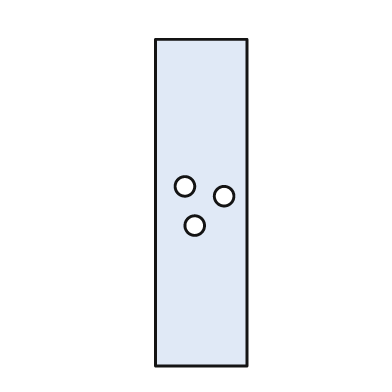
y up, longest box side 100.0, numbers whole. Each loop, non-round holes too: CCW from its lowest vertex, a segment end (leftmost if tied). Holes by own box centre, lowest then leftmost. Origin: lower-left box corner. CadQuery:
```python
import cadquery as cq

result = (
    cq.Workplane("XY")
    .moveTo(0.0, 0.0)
    .lineTo(28.0, 0.0)
    .lineTo(28.0, 100.0)
    .lineTo(0.0, 100.0)
    .close()
    .moveTo(12.0, 43.0)
    .circle(3.0)
    .moveTo(21.0, 52.0)
    .circle(3.0)
    .moveTo(9.0, 55.0)
    .circle(3.0)
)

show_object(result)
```